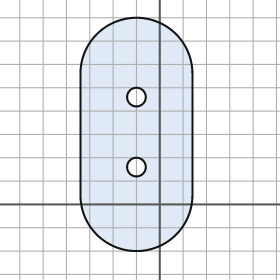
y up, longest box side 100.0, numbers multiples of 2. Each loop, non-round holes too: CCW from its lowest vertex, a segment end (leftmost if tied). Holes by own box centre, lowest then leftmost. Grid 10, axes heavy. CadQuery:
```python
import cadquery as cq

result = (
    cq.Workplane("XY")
    .moveTo(-34.0, 4.0)
    .threePointArc((-10.0, -20.0), (14.0, 4.0))
    .lineTo(14.0, 56.0)
    .threePointArc((-10.0, 80.0), (-34.0, 56.0))
    .close()
    .moveTo(-10.0, 16.0)
    .circle(4.0)
    .moveTo(-10.0, 46.0)
    .circle(4.0)
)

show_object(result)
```